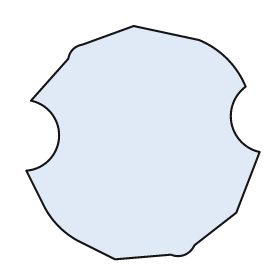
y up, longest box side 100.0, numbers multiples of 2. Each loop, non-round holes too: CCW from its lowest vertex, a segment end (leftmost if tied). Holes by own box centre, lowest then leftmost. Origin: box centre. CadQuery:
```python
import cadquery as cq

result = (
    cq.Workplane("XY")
    .moveTo(-12.0, -50.0)
    .lineTo(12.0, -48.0)
    .threePointArc((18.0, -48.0), (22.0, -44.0))
    .lineTo(40.0, -30.0)
    .lineTo(50.0, -4.0)
    .threePointArc((38.0, 8.0), (44.0, 24.0))
    .threePointArc((36.0, 36.0), (24.0, 44.0))
    .lineTo(-4.0, 50.0)
    .lineTo(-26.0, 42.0)
    .threePointArc((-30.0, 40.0), (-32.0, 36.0))
    .lineTo(-48.0, 18.0)
    .threePointArc((-36.0, 2.0), (-50.0, -12.0))
    .lineTo(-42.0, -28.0)
    .threePointArc((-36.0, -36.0), (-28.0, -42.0))
    .close()
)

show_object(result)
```